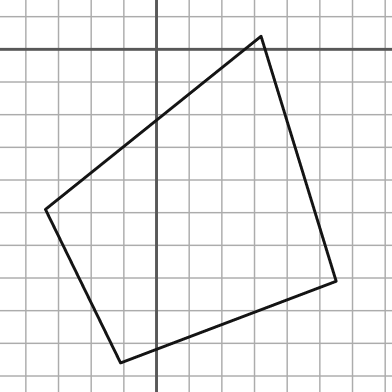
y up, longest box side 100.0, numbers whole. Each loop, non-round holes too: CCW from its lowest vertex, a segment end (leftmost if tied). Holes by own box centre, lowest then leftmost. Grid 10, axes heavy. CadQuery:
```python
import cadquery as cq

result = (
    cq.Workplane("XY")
    .moveTo(-11.0, -96.0)
    .lineTo(55.0, -71.0)
    .lineTo(32.0, 4.0)
    .lineTo(-34.0, -49.0)
    .close()
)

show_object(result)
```